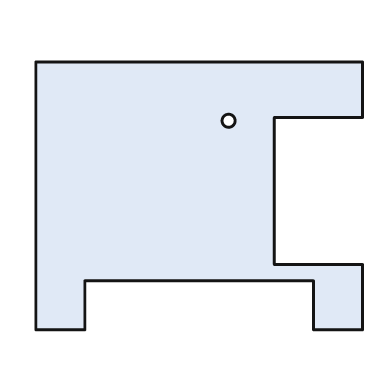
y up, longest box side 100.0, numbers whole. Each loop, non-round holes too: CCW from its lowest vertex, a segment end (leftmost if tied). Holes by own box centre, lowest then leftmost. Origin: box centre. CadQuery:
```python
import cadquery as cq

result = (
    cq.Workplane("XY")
    .moveTo(-50.0, -41.0)
    .lineTo(-35.0, -41.0)
    .lineTo(-35.0, -26.0)
    .lineTo(35.0, -26.0)
    .lineTo(35.0, -41.0)
    .lineTo(50.0, -41.0)
    .lineTo(50.0, -21.0)
    .lineTo(23.0, -21.0)
    .lineTo(23.0, 24.0)
    .lineTo(50.0, 24.0)
    .lineTo(50.0, 41.0)
    .lineTo(-50.0, 41.0)
    .close()
    .moveTo(9.0, 23.0)
    .circle(2.0)
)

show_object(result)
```